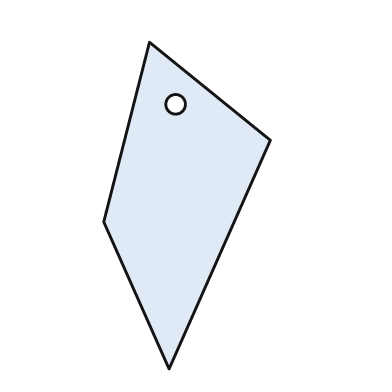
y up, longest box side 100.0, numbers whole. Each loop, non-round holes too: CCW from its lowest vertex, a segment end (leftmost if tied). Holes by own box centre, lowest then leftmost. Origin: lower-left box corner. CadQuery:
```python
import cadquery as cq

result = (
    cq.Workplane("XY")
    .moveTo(20.0, 0.0)
    .lineTo(51.0, 70.0)
    .lineTo(14.0, 100.0)
    .lineTo(0.0, 45.0)
    .close()
    .moveTo(22.0, 81.0)
    .circle(3.0)
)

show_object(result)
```